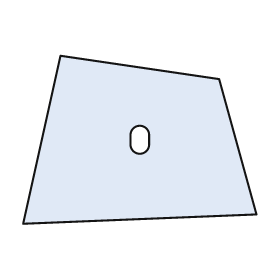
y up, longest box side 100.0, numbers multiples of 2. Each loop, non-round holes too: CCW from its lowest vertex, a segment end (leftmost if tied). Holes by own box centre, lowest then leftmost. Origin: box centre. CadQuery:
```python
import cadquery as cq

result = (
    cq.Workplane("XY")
    .moveTo(-50.0, -36.0)
    .lineTo(50.0, -32.0)
    .lineTo(34.0, 26.0)
    .lineTo(-34.0, 36.0)
    .close()
    .moveTo(-4.0, -2.0)
    .threePointArc((0.0, -6.0), (4.0, -2.0))
    .lineTo(4.0, 2.0)
    .threePointArc((0.0, 6.0), (-4.0, 2.0))
    .close()
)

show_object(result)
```